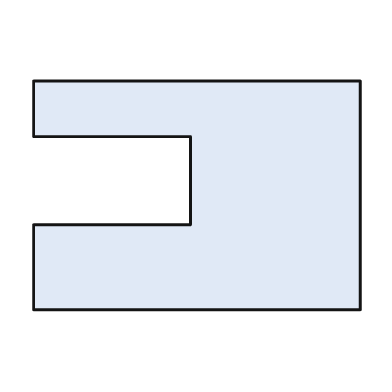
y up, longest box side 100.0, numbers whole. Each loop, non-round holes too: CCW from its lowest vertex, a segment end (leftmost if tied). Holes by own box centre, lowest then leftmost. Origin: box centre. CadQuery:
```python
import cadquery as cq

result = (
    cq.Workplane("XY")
    .moveTo(-50.0, -35.0)
    .lineTo(50.0, -35.0)
    .lineTo(50.0, 35.0)
    .lineTo(-50.0, 35.0)
    .lineTo(-50.0, 18.0)
    .lineTo(-2.0, 18.0)
    .lineTo(-2.0, -9.0)
    .lineTo(-50.0, -9.0)
    .close()
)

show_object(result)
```